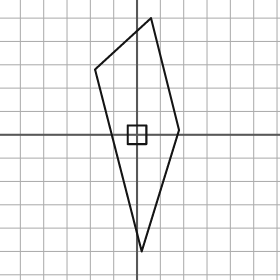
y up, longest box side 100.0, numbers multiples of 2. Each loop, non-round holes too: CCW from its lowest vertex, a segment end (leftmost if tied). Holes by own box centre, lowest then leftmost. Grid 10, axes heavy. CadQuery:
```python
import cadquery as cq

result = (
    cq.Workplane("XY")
    .moveTo(2.0, -50.0)
    .lineTo(18.0, 2.0)
    .lineTo(6.0, 50.0)
    .lineTo(-18.0, 28.0)
    .close()
    .moveTo(-4.0, -4.0)
    .lineTo(4.0, -4.0)
    .lineTo(4.0, 4.0)
    .lineTo(-4.0, 4.0)
    .close()
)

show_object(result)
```